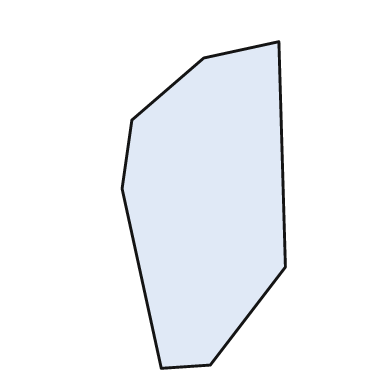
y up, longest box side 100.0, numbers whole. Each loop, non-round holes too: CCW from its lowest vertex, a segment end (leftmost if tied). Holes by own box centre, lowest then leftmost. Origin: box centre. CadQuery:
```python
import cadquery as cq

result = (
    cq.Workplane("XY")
    .moveTo(-13.0, -50.0)
    .lineTo(2.0, -49.0)
    .lineTo(25.0, -19.0)
    .lineTo(23.0, 50.0)
    .lineTo(0.0, 45.0)
    .lineTo(-22.0, 26.0)
    .lineTo(-25.0, 5.0)
    .close()
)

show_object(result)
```